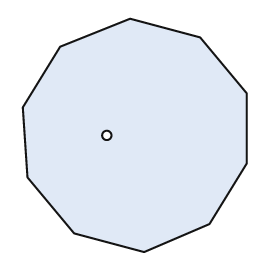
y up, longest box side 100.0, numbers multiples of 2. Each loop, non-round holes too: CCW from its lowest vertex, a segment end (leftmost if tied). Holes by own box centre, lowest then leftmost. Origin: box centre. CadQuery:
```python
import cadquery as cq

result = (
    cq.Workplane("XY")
    .moveTo(4.0, -50.0)
    .lineTo(32.0, -38.0)
    .lineTo(48.0, -12.0)
    .lineTo(48.0, 18.0)
    .lineTo(28.0, 42.0)
    .lineTo(-2.0, 50.0)
    .lineTo(-32.0, 38.0)
    .lineTo(-48.0, 12.0)
    .lineTo(-46.0, -18.0)
    .lineTo(-26.0, -42.0)
    .close()
    .moveTo(-12.0, 0.0)
    .circle(2.0)
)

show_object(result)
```